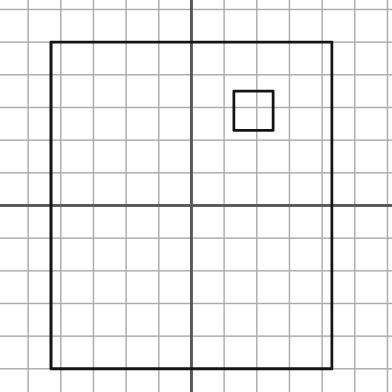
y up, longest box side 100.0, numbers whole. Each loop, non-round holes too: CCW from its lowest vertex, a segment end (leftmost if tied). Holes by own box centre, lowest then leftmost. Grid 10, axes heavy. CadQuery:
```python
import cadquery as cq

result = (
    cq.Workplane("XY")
    .moveTo(-43.0, -50.0)
    .lineTo(43.0, -50.0)
    .lineTo(43.0, 50.0)
    .lineTo(-43.0, 50.0)
    .close()
    .moveTo(13.0, 23.0)
    .lineTo(25.0, 23.0)
    .lineTo(25.0, 35.0)
    .lineTo(13.0, 35.0)
    .close()
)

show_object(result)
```